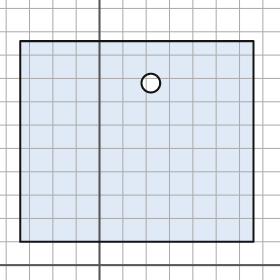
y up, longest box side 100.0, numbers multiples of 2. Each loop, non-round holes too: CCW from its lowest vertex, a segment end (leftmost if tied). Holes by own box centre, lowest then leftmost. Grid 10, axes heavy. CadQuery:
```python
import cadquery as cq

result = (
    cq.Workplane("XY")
    .moveTo(-34.0, 10.0)
    .lineTo(66.0, 10.0)
    .lineTo(66.0, 96.0)
    .lineTo(-34.0, 96.0)
    .close()
    .moveTo(22.0, 78.0)
    .circle(4.0)
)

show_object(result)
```